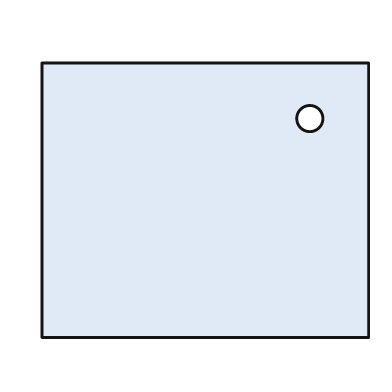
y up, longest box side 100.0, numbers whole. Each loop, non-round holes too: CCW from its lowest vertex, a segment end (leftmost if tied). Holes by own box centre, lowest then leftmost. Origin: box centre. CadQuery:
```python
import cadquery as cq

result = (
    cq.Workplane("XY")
    .moveTo(-50.0, -42.0)
    .lineTo(50.0, -42.0)
    .lineTo(50.0, 42.0)
    .lineTo(-50.0, 42.0)
    .close()
    .moveTo(32.0, 25.0)
    .circle(4.0)
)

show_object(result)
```